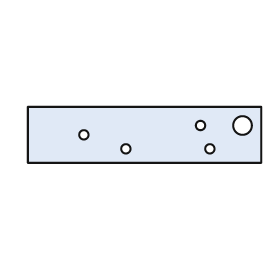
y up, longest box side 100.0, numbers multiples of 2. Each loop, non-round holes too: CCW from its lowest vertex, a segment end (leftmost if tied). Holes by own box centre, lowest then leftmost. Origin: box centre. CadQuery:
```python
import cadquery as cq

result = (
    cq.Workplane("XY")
    .moveTo(-50.0, -12.0)
    .lineTo(50.0, -12.0)
    .lineTo(50.0, 12.0)
    .lineTo(-50.0, 12.0)
    .close()
    .moveTo(-8.0, -6.0)
    .circle(2.0)
    .moveTo(28.0, -6.0)
    .circle(2.0)
    .moveTo(-26.0, 0.0)
    .circle(2.0)
    .moveTo(24.0, 4.0)
    .circle(2.0)
    .moveTo(42.0, 4.0)
    .circle(4.0)
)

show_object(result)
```